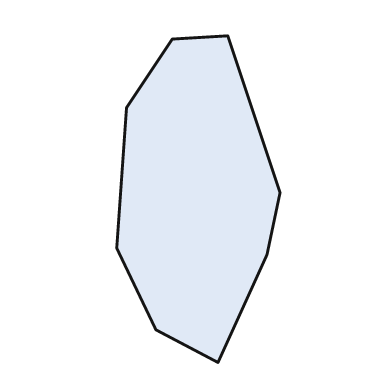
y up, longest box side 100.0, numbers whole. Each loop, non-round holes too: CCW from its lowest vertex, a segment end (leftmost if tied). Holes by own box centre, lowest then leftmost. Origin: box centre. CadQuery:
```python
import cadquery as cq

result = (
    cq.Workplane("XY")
    .moveTo(6.0, -50.0)
    .lineTo(21.0, -17.0)
    .lineTo(25.0, 2.0)
    .lineTo(9.0, 50.0)
    .lineTo(-8.0, 49.0)
    .lineTo(-22.0, 28.0)
    .lineTo(-25.0, -15.0)
    .lineTo(-13.0, -40.0)
    .close()
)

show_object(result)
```